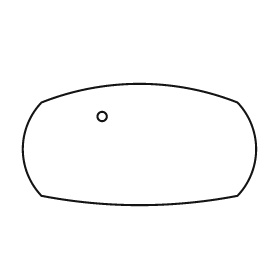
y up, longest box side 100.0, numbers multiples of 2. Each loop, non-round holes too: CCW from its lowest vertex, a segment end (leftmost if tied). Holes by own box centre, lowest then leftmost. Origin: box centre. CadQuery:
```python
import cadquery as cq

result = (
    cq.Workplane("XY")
    .moveTo(-42.0, -22.0)
    .threePointArc((0.0, -26.0), (42.0, -22.0))
    .threePointArc((50.0, -2.0), (42.0, 18.0))
    .threePointArc((0.0, 26.0), (-42.0, 18.0))
    .threePointArc((-50.0, -2.0), (-42.0, -22.0))
    .close()
    .moveTo(-16.0, 12.0)
    .circle(2.0)
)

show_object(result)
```